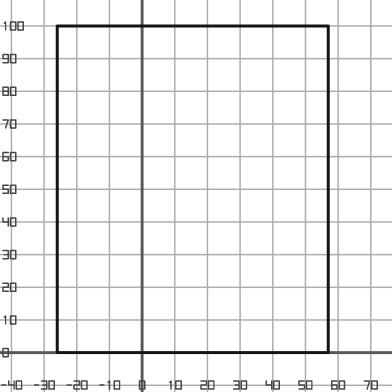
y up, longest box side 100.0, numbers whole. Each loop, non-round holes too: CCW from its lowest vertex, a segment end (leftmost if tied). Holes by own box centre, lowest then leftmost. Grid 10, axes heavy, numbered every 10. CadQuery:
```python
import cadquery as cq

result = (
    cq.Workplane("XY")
    .moveTo(-26.0, 0.0)
    .lineTo(57.0, 0.0)
    .lineTo(57.0, 100.0)
    .lineTo(-26.0, 100.0)
    .close()
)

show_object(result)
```